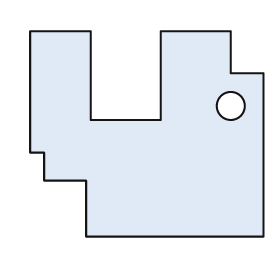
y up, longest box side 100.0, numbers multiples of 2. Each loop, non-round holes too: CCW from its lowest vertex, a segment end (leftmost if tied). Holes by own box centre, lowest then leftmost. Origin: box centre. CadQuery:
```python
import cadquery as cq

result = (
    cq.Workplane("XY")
    .moveTo(-26.0, -44.0)
    .lineTo(50.0, -44.0)
    .lineTo(50.0, 26.0)
    .lineTo(36.0, 26.0)
    .lineTo(36.0, 44.0)
    .lineTo(6.0, 44.0)
    .lineTo(6.0, 6.0)
    .lineTo(-24.0, 6.0)
    .lineTo(-24.0, 44.0)
    .lineTo(-50.0, 44.0)
    .lineTo(-50.0, -8.0)
    .lineTo(-44.0, -8.0)
    .lineTo(-44.0, -20.0)
    .lineTo(-26.0, -20.0)
    .close()
    .moveTo(36.0, 12.0)
    .circle(6.0)
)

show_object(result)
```